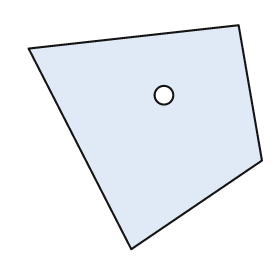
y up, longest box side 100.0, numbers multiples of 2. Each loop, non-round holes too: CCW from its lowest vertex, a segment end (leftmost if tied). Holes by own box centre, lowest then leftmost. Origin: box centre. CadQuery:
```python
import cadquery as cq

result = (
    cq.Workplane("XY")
    .moveTo(-6.0, -48.0)
    .lineTo(50.0, -10.0)
    .lineTo(40.0, 48.0)
    .lineTo(-50.0, 38.0)
    .close()
    .moveTo(8.0, 18.0)
    .circle(4.0)
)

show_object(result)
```